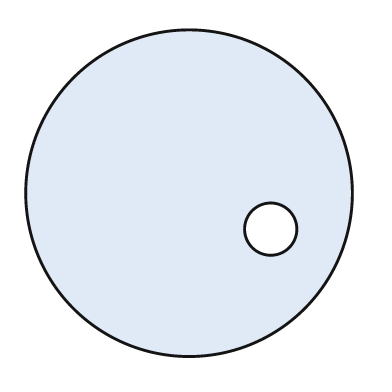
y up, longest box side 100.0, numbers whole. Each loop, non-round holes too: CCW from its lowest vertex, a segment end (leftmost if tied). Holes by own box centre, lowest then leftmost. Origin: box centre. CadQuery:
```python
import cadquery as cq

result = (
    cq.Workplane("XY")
    .moveTo(0.0, 0.0)
    .circle(50.0)
    .moveTo(25.0, -11.0)
    .circle(8.0)
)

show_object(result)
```